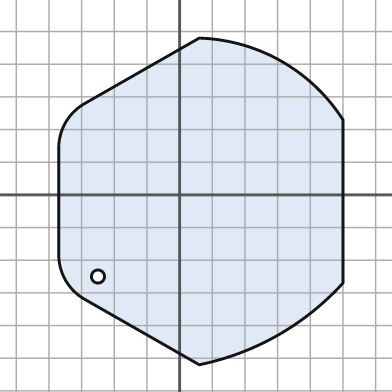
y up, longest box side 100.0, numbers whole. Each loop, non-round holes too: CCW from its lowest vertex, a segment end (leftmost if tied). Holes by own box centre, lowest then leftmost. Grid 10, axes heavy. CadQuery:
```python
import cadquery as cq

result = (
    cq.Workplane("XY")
    .moveTo(6.0, -52.0)
    .threePointArc((30.0, -43.0), (50.0, -27.0))
    .lineTo(50.0, 23.0)
    .threePointArc((31.0, 41.0), (6.0, 48.0))
    .lineTo(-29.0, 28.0)
    .threePointArc((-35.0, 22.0), (-37.0, 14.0))
    .lineTo(-37.0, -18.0)
    .threePointArc((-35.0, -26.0), (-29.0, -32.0))
    .close()
    .moveTo(-25.0, -25.0)
    .circle(2.0)
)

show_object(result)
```